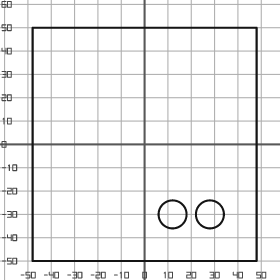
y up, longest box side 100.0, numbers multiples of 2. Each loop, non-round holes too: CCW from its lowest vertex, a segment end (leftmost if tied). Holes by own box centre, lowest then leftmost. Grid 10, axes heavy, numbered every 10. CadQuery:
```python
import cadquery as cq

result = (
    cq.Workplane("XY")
    .moveTo(-48.0, -50.0)
    .lineTo(48.0, -50.0)
    .lineTo(48.0, 50.0)
    .lineTo(-48.0, 50.0)
    .close()
    .moveTo(12.0, -30.0)
    .circle(6.0)
    .moveTo(28.0, -30.0)
    .circle(6.0)
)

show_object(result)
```